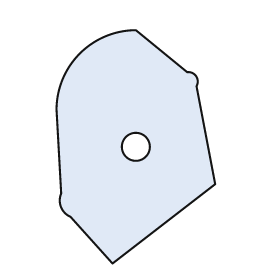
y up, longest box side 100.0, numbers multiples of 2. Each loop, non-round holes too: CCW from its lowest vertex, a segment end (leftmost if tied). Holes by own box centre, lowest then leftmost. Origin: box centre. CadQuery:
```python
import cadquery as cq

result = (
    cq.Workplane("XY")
    .moveTo(-10.0, -50.0)
    .lineTo(34.0, -16.0)
    .lineTo(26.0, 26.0)
    .threePointArc((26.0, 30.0), (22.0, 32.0))
    .lineTo(0.0, 50.0)
    .threePointArc((-24.0, 40.0), (-34.0, 16.0))
    .lineTo(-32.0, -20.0)
    .threePointArc((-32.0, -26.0), (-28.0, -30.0))
    .close()
    .moveTo(0.0, 0.0)
    .circle(6.0)
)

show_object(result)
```